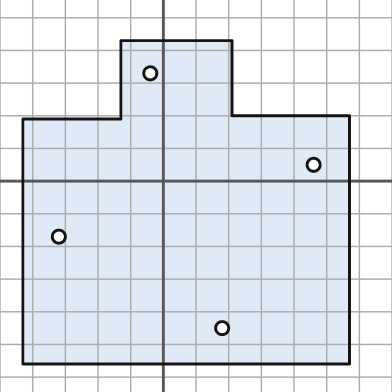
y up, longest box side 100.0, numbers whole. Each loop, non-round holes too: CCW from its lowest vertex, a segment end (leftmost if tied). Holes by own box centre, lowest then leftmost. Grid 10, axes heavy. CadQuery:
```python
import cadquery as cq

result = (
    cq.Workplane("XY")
    .moveTo(-43.0, -56.0)
    .lineTo(57.0, -56.0)
    .lineTo(57.0, 20.0)
    .lineTo(21.0, 20.0)
    .lineTo(21.0, 43.0)
    .lineTo(-13.0, 43.0)
    .lineTo(-13.0, 19.0)
    .lineTo(-43.0, 19.0)
    .close()
    .moveTo(18.0, -45.0)
    .circle(2.0)
    .moveTo(-32.0, -17.0)
    .circle(2.0)
    .moveTo(46.0, 5.0)
    .circle(2.0)
    .moveTo(-4.0, 33.0)
    .circle(2.0)
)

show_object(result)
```